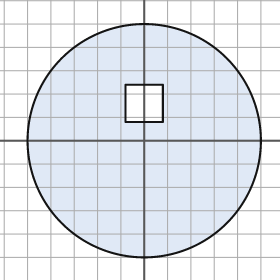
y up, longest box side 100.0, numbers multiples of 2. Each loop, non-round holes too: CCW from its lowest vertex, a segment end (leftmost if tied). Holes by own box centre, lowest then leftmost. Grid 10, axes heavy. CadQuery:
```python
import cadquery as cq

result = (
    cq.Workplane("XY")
    .moveTo(0.0, 0.0)
    .circle(50.0)
    .moveTo(-8.0, 8.0)
    .lineTo(8.0, 8.0)
    .lineTo(8.0, 24.0)
    .lineTo(-8.0, 24.0)
    .close()
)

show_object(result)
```